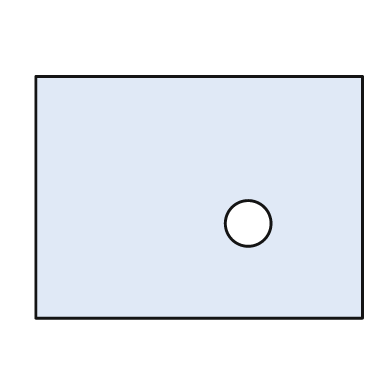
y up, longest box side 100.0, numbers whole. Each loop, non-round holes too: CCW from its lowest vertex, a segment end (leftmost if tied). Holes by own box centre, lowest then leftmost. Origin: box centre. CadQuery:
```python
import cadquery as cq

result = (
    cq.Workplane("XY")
    .moveTo(-50.0, -37.0)
    .lineTo(50.0, -37.0)
    .lineTo(50.0, 37.0)
    .lineTo(-50.0, 37.0)
    .close()
    .moveTo(15.0, -8.0)
    .circle(7.0)
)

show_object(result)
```